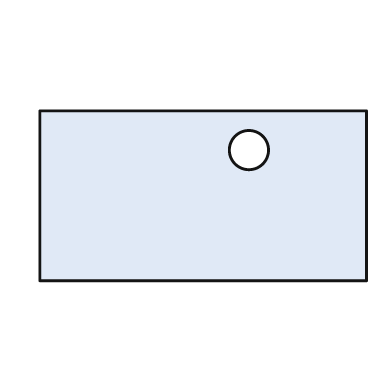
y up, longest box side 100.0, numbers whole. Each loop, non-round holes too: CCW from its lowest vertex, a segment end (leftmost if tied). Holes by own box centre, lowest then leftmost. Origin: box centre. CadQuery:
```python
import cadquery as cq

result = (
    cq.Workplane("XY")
    .moveTo(-50.0, -26.0)
    .lineTo(50.0, -26.0)
    .lineTo(50.0, 26.0)
    .lineTo(-50.0, 26.0)
    .close()
    .moveTo(14.0, 14.0)
    .circle(6.0)
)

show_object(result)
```